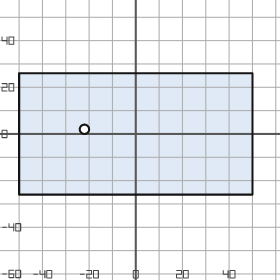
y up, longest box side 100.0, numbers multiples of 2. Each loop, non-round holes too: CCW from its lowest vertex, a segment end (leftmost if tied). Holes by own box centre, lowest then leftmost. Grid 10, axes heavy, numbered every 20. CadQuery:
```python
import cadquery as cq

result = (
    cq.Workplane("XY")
    .moveTo(-50.0, -26.0)
    .lineTo(50.0, -26.0)
    .lineTo(50.0, 26.0)
    .lineTo(-50.0, 26.0)
    .close()
    .moveTo(-22.0, 2.0)
    .circle(2.0)
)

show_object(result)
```